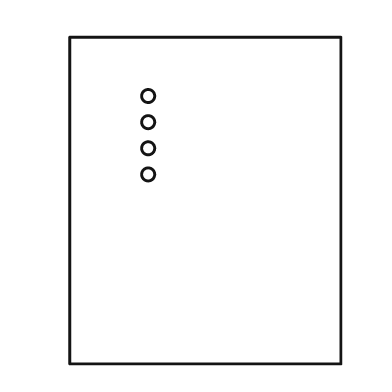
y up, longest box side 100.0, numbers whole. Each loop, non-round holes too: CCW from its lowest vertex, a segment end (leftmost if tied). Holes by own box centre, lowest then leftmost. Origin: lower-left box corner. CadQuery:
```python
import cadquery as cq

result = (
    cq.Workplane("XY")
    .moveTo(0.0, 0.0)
    .lineTo(83.0, 0.0)
    .lineTo(83.0, 100.0)
    .lineTo(0.0, 100.0)
    .close()
    .moveTo(24.0, 58.0)
    .circle(2.0)
    .moveTo(24.0, 66.0)
    .circle(2.0)
    .moveTo(24.0, 74.0)
    .circle(2.0)
    .moveTo(24.0, 82.0)
    .circle(2.0)
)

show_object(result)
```